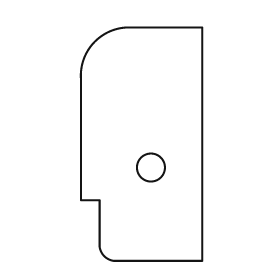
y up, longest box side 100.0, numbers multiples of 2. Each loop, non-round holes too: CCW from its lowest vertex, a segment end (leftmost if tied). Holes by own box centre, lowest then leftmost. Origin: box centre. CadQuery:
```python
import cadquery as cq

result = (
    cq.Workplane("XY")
    .moveTo(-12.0, -50.0)
    .lineTo(26.0, -50.0)
    .lineTo(26.0, 50.0)
    .lineTo(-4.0, 50.0)
    .threePointArc((-20.0, 44.0), (-26.0, 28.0))
    .lineTo(-26.0, -24.0)
    .lineTo(-18.0, -24.0)
    .lineTo(-18.0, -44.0)
    .threePointArc((-16.0, -48.0), (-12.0, -50.0))
    .close()
    .moveTo(4.0, -10.0)
    .circle(6.0)
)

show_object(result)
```